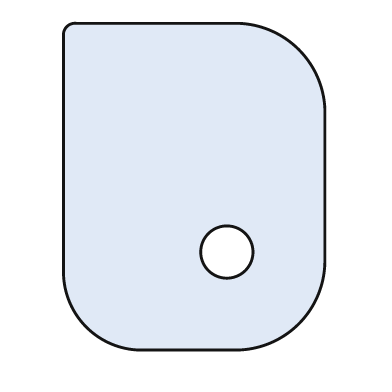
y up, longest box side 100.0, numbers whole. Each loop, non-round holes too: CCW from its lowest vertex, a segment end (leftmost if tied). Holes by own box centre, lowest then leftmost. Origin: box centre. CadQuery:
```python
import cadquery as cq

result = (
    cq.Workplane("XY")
    .moveTo(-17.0, -50.0)
    .lineTo(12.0, -50.0)
    .threePointArc((32.0, -42.0), (40.0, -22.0))
    .lineTo(40.0, 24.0)
    .threePointArc((32.0, 42.0), (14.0, 50.0))
    .lineTo(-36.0, 50.0)
    .threePointArc((-39.0, 49.0), (-40.0, 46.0))
    .lineTo(-40.0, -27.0)
    .threePointArc((-33.0, -43.0), (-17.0, -50.0))
    .close()
    .moveTo(10.0, -20.0)
    .circle(8.0)
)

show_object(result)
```